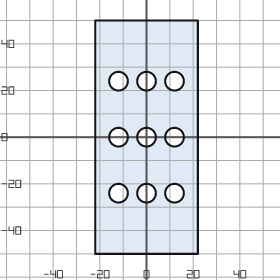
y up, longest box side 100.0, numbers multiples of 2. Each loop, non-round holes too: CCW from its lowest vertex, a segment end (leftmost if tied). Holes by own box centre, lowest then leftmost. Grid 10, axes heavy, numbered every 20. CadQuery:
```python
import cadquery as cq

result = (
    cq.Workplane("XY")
    .moveTo(-22.0, -50.0)
    .lineTo(22.0, -50.0)
    .lineTo(22.0, 50.0)
    .lineTo(-22.0, 50.0)
    .close()
    .moveTo(-12.0, -24.0)
    .circle(4.0)
    .moveTo(0.0, -24.0)
    .circle(4.0)
    .moveTo(12.0, -24.0)
    .circle(4.0)
    .moveTo(-12.0, 0.0)
    .circle(4.0)
    .moveTo(0.0, 0.0)
    .circle(4.0)
    .moveTo(12.0, 0.0)
    .circle(4.0)
    .moveTo(-12.0, 24.0)
    .circle(4.0)
    .moveTo(0.0, 24.0)
    .circle(4.0)
    .moveTo(12.0, 24.0)
    .circle(4.0)
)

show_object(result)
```